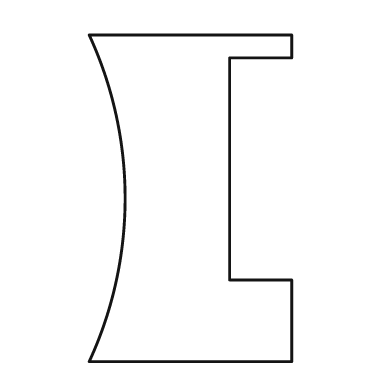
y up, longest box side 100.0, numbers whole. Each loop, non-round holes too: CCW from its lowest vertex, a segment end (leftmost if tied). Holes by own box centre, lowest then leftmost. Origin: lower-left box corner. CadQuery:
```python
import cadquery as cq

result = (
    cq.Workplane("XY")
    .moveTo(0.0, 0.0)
    .lineTo(62.0, 0.0)
    .lineTo(62.0, 25.0)
    .lineTo(43.0, 25.0)
    .lineTo(43.0, 93.0)
    .lineTo(62.0, 93.0)
    .lineTo(62.0, 100.0)
    .lineTo(0.0, 100.0)
    .threePointArc((11.0, 50.0), (0.0, 0.0))
    .close()
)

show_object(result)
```